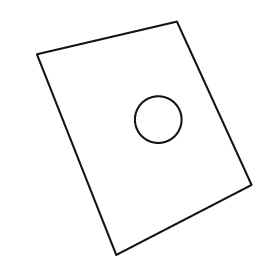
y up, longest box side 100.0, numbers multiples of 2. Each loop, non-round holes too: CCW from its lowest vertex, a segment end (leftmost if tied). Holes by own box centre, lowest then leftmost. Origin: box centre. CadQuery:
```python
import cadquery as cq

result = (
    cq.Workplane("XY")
    .moveTo(-12.0, -50.0)
    .lineTo(46.0, -20.0)
    .lineTo(14.0, 50.0)
    .lineTo(-46.0, 36.0)
    .close()
    .moveTo(6.0, 8.0)
    .circle(10.0)
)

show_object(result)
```